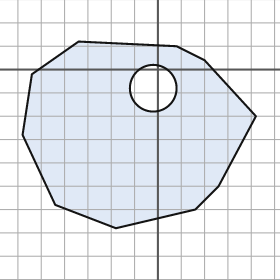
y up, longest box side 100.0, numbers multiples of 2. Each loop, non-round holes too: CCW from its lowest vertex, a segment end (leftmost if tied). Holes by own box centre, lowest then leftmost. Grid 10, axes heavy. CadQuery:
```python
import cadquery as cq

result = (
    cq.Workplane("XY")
    .moveTo(-18.0, -68.0)
    .lineTo(16.0, -60.0)
    .lineTo(26.0, -50.0)
    .lineTo(42.0, -20.0)
    .lineTo(20.0, 4.0)
    .lineTo(8.0, 10.0)
    .lineTo(-34.0, 12.0)
    .lineTo(-54.0, -2.0)
    .lineTo(-58.0, -28.0)
    .lineTo(-44.0, -58.0)
    .close()
    .moveTo(-2.0, -8.0)
    .circle(10.0)
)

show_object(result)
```